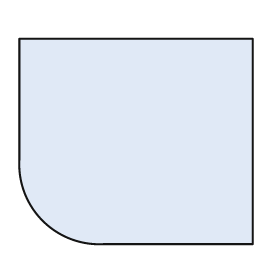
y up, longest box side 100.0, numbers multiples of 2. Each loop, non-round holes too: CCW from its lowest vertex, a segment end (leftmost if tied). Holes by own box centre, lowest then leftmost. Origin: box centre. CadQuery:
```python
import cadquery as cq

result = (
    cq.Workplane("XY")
    .moveTo(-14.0, -44.0)
    .lineTo(50.0, -44.0)
    .lineTo(50.0, 44.0)
    .lineTo(-50.0, 44.0)
    .lineTo(-50.0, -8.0)
    .threePointArc((-40.0, -34.0), (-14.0, -44.0))
    .close()
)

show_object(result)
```